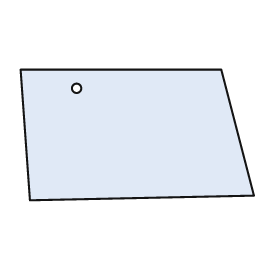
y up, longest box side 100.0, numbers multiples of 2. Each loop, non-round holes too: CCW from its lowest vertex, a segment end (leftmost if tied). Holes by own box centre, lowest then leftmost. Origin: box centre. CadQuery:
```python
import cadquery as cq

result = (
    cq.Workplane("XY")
    .moveTo(-46.0, -28.0)
    .lineTo(50.0, -26.0)
    .lineTo(36.0, 28.0)
    .lineTo(-50.0, 28.0)
    .close()
    .moveTo(-26.0, 20.0)
    .circle(2.0)
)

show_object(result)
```